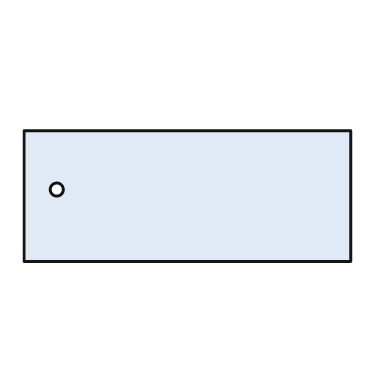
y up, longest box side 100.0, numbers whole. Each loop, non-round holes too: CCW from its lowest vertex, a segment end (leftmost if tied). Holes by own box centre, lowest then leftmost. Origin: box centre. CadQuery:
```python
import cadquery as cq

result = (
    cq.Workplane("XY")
    .moveTo(-50.0, -20.0)
    .lineTo(50.0, -20.0)
    .lineTo(50.0, 20.0)
    .lineTo(-50.0, 20.0)
    .close()
    .moveTo(-40.0, 2.0)
    .circle(2.0)
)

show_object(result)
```